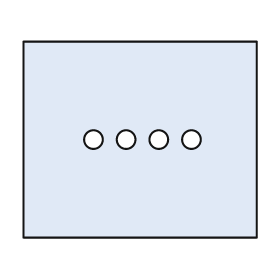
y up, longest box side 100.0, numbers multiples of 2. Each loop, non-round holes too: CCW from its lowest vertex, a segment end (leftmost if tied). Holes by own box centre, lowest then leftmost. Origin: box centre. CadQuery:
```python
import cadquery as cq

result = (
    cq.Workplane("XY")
    .moveTo(-50.0, -42.0)
    .lineTo(50.0, -42.0)
    .lineTo(50.0, 42.0)
    .lineTo(-50.0, 42.0)
    .close()
    .moveTo(-20.0, 0.0)
    .circle(4.0)
    .moveTo(-6.0, 0.0)
    .circle(4.0)
    .moveTo(8.0, 0.0)
    .circle(4.0)
    .moveTo(22.0, 0.0)
    .circle(4.0)
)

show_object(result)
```